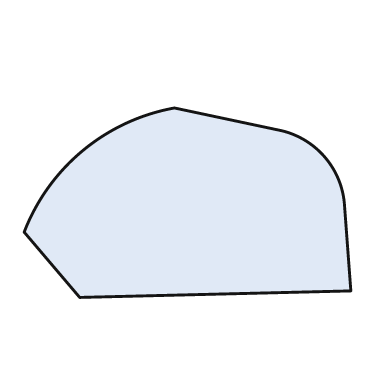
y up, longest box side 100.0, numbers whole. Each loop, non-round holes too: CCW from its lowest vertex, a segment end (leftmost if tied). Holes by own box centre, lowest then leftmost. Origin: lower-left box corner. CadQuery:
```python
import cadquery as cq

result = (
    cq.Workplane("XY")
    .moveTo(17.0, 0.0)
    .lineTo(100.0, 2.0)
    .lineTo(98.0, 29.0)
    .threePointArc((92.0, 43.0), (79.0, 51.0))
    .lineTo(46.0, 58.0)
    .threePointArc((18.0, 45.0), (0.0, 20.0))
    .close()
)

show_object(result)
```